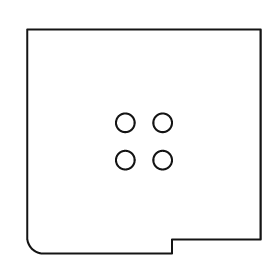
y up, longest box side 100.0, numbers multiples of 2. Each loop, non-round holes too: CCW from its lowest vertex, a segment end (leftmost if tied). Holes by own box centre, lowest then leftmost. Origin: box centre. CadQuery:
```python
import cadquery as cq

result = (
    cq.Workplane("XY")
    .moveTo(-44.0, -48.0)
    .lineTo(12.0, -48.0)
    .lineTo(12.0, -42.0)
    .lineTo(50.0, -42.0)
    .lineTo(50.0, 48.0)
    .lineTo(-50.0, 48.0)
    .lineTo(-50.0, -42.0)
    .threePointArc((-48.0, -46.0), (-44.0, -48.0))
    .close()
    .moveTo(-8.0, -8.0)
    .circle(4.0)
    .moveTo(8.0, -8.0)
    .circle(4.0)
    .moveTo(-8.0, 8.0)
    .circle(4.0)
    .moveTo(8.0, 8.0)
    .circle(4.0)
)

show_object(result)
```